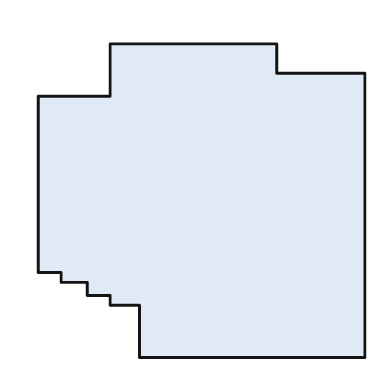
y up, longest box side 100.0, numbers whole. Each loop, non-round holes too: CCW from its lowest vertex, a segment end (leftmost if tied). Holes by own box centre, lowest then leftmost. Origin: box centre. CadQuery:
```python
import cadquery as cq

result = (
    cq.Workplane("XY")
    .moveTo(-19.0, -48.0)
    .lineTo(50.0, -48.0)
    .lineTo(50.0, 39.0)
    .lineTo(23.0, 39.0)
    .lineTo(23.0, 48.0)
    .lineTo(-28.0, 48.0)
    .lineTo(-28.0, 32.0)
    .lineTo(-50.0, 32.0)
    .lineTo(-50.0, -22.0)
    .lineTo(-43.0, -22.0)
    .lineTo(-43.0, -25.0)
    .lineTo(-35.0, -25.0)
    .lineTo(-35.0, -29.0)
    .lineTo(-28.0, -29.0)
    .lineTo(-28.0, -32.0)
    .lineTo(-19.0, -32.0)
    .close()
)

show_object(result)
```